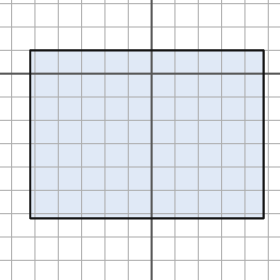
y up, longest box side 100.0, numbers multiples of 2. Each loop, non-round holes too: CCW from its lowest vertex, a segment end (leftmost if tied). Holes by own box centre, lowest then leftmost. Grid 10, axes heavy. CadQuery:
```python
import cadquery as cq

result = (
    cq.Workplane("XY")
    .moveTo(-52.0, -62.0)
    .lineTo(48.0, -62.0)
    .lineTo(48.0, 10.0)
    .lineTo(-52.0, 10.0)
    .close()
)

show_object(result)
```